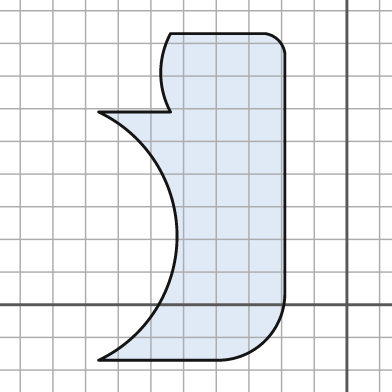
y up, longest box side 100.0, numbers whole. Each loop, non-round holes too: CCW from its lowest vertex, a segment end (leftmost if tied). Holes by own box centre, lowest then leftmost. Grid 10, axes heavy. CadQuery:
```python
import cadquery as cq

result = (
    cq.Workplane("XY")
    .moveTo(-76.0, -17.0)
    .lineTo(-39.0, -17.0)
    .threePointArc((-25.0, -11.0), (-19.0, 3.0))
    .lineTo(-19.0, 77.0)
    .threePointArc((-21.0, 81.0), (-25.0, 83.0))
    .lineTo(-54.0, 83.0)
    .threePointArc((-57.0, 71.0), (-54.0, 59.0))
    .lineTo(-76.0, 59.0)
    .threePointArc((-52.0, 21.0), (-76.0, -17.0))
    .close()
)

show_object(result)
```